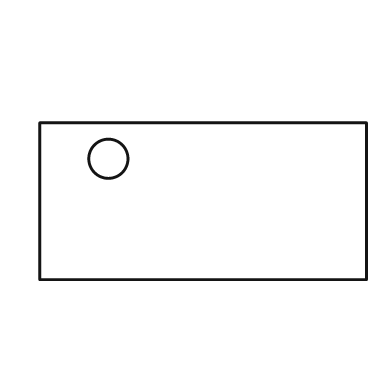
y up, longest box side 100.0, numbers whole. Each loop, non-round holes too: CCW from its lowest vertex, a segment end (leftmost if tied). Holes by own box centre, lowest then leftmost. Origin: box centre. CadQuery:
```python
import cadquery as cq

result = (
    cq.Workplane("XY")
    .moveTo(-50.0, -24.0)
    .lineTo(50.0, -24.0)
    .lineTo(50.0, 24.0)
    .lineTo(-50.0, 24.0)
    .close()
    .moveTo(-29.0, 13.0)
    .circle(6.0)
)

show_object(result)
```